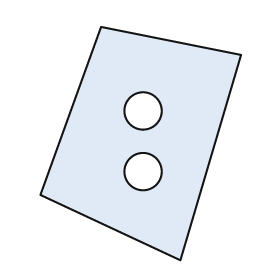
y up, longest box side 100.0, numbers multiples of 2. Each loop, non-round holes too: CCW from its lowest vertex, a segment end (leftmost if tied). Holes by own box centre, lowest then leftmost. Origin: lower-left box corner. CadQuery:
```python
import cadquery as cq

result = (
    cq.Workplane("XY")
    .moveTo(60.0, 0.0)
    .lineTo(86.0, 88.0)
    .lineTo(26.0, 100.0)
    .lineTo(0.0, 28.0)
    .close()
    .moveTo(44.0, 38.0)
    .circle(8.0)
    .moveTo(44.0, 64.0)
    .circle(8.0)
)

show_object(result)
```